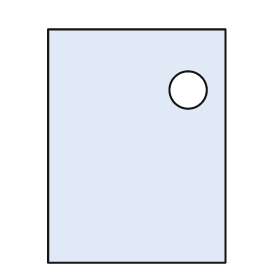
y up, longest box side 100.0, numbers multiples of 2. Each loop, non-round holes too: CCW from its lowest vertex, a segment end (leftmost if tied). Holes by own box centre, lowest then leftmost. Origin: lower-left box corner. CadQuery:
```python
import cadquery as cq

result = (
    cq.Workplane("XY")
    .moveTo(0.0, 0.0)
    .lineTo(76.0, 0.0)
    .lineTo(76.0, 100.0)
    .lineTo(0.0, 100.0)
    .close()
    .moveTo(60.0, 74.0)
    .circle(8.0)
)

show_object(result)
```